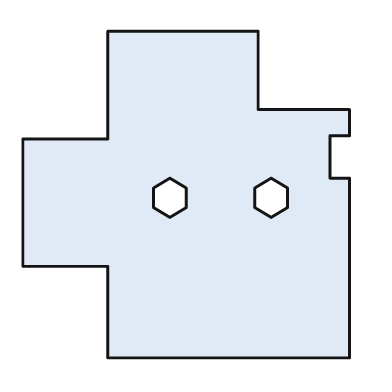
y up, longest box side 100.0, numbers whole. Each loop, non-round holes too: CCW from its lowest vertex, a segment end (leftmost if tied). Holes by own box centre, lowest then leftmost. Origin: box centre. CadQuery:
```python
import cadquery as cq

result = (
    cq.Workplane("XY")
    .moveTo(-24.0, -50.0)
    .lineTo(50.0, -50.0)
    .lineTo(50.0, 5.0)
    .lineTo(44.0, 5.0)
    .lineTo(44.0, 18.0)
    .lineTo(50.0, 18.0)
    .lineTo(50.0, 26.0)
    .lineTo(22.0, 26.0)
    .lineTo(22.0, 50.0)
    .lineTo(-24.0, 50.0)
    .lineTo(-24.0, 17.0)
    .lineTo(-50.0, 17.0)
    .lineTo(-50.0, -22.0)
    .lineTo(-24.0, -22.0)
    .close()
    .moveTo(-5.0, -7.0)
    .lineTo(0.0, -4.0)
    .lineTo(0.0, 2.0)
    .lineTo(-5.0, 5.0)
    .lineTo(-10.0, 2.0)
    .lineTo(-10.0, -4.0)
    .close()
    .moveTo(26.0, -7.0)
    .lineTo(31.0, -4.0)
    .lineTo(31.0, 2.0)
    .lineTo(26.0, 5.0)
    .lineTo(21.0, 2.0)
    .lineTo(21.0, -4.0)
    .close()
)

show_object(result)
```